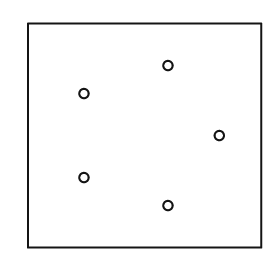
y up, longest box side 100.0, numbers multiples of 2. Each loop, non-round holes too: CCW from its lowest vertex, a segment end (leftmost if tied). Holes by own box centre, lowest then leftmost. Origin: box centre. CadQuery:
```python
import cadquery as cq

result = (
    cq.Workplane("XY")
    .moveTo(-50.0, -48.0)
    .lineTo(50.0, -48.0)
    .lineTo(50.0, 48.0)
    .lineTo(-50.0, 48.0)
    .close()
    .moveTo(10.0, -30.0)
    .circle(2.0)
    .moveTo(-26.0, -18.0)
    .circle(2.0)
    .moveTo(32.0, 0.0)
    .circle(2.0)
    .moveTo(-26.0, 18.0)
    .circle(2.0)
    .moveTo(10.0, 30.0)
    .circle(2.0)
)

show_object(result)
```